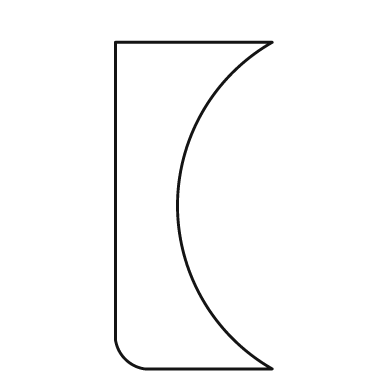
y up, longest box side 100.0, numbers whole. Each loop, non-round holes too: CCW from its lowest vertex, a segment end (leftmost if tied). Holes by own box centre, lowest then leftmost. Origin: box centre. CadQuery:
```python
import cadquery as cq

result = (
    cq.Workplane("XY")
    .moveTo(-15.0, -50.0)
    .lineTo(24.0, -50.0)
    .threePointArc((-5.0, 0.0), (24.0, 50.0))
    .lineTo(-24.0, 50.0)
    .lineTo(-24.0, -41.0)
    .threePointArc((-21.0, -47.0), (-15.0, -50.0))
    .close()
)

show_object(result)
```